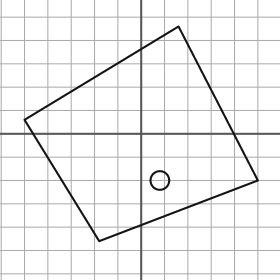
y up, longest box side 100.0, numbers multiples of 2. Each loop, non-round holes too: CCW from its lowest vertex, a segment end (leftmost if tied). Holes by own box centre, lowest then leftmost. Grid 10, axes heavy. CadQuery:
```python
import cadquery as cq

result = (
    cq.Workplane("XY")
    .moveTo(-18.0, -46.0)
    .lineTo(50.0, -20.0)
    .lineTo(16.0, 46.0)
    .lineTo(-50.0, 6.0)
    .close()
    .moveTo(8.0, -20.0)
    .circle(4.0)
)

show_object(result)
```